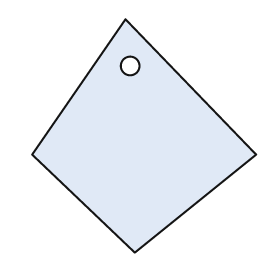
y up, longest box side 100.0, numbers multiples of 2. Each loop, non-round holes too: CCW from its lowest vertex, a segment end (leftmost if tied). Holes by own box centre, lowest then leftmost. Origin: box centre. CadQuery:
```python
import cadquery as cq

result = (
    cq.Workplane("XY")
    .moveTo(-4.0, -50.0)
    .lineTo(48.0, -8.0)
    .lineTo(-8.0, 50.0)
    .lineTo(-48.0, -8.0)
    .close()
    .moveTo(-6.0, 30.0)
    .circle(4.0)
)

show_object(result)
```